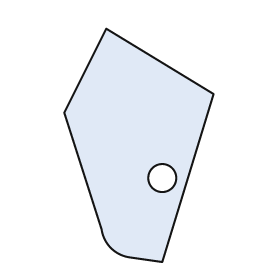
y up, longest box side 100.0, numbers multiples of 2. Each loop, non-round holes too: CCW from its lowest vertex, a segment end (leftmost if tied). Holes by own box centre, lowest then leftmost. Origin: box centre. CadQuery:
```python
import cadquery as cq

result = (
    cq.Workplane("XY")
    .moveTo(10.0, -50.0)
    .lineTo(32.0, 22.0)
    .lineTo(-14.0, 50.0)
    .lineTo(-32.0, 14.0)
    .lineTo(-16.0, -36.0)
    .threePointArc((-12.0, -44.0), (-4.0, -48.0))
    .close()
    .moveTo(10.0, -14.0)
    .circle(6.0)
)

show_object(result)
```